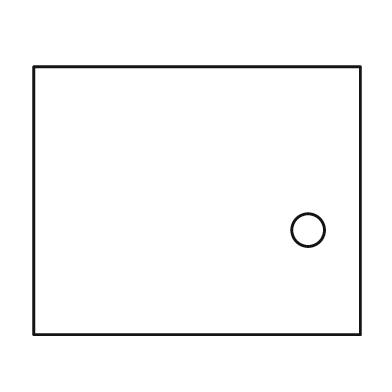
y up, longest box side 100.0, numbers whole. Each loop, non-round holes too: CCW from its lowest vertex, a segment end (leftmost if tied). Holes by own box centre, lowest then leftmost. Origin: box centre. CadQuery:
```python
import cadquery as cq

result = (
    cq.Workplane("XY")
    .moveTo(-50.0, -41.0)
    .lineTo(50.0, -41.0)
    .lineTo(50.0, 41.0)
    .lineTo(-50.0, 41.0)
    .close()
    .moveTo(34.0, -9.0)
    .circle(5.0)
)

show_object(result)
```